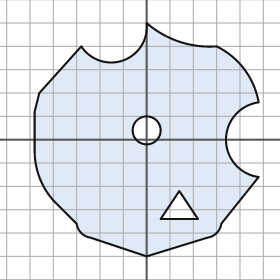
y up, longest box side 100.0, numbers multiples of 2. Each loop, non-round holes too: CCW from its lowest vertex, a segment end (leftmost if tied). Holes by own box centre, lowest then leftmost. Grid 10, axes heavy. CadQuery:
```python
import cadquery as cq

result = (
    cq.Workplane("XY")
    .moveTo(0.0, -50.0)
    .lineTo(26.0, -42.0)
    .threePointArc((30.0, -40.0), (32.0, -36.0))
    .lineTo(48.0, -16.0)
    .threePointArc((34.0, 0.0), (48.0, 16.0))
    .threePointArc((42.0, 30.0), (30.0, 40.0))
    .threePointArc((14.0, 42.0), (0.0, 50.0))
    .threePointArc((-10.0, 34.0), (-28.0, 40.0))
    .lineTo(-46.0, 20.0)
    .lineTo(-48.0, 12.0)
    .lineTo(-48.0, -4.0)
    .threePointArc((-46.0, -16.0), (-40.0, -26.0))
    .lineTo(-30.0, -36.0)
    .threePointArc((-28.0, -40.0), (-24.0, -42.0))
    .close()
    .moveTo(6.0, -34.0)
    .lineTo(22.0, -34.0)
    .lineTo(14.0, -22.0)
    .close()
    .moveTo(0.0, 4.0)
    .circle(6.0)
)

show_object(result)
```